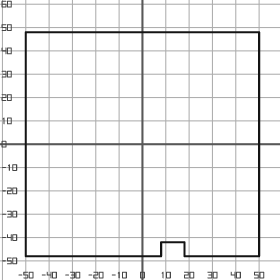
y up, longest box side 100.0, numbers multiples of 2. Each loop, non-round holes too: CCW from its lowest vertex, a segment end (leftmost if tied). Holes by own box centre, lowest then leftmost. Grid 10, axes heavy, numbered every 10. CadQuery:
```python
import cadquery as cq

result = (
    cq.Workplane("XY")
    .moveTo(-50.0, -48.0)
    .lineTo(8.0, -48.0)
    .lineTo(8.0, -42.0)
    .lineTo(18.0, -42.0)
    .lineTo(18.0, -48.0)
    .lineTo(50.0, -48.0)
    .lineTo(50.0, 48.0)
    .lineTo(-50.0, 48.0)
    .close()
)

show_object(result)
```